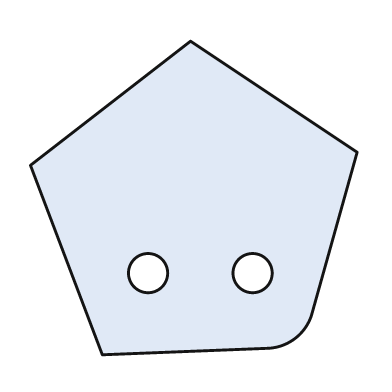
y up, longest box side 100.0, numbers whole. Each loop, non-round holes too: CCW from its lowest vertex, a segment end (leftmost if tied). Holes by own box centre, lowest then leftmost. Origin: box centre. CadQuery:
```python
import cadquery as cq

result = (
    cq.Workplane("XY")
    .moveTo(-28.0, -48.0)
    .lineTo(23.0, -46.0)
    .threePointArc((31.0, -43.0), (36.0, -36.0))
    .lineTo(50.0, 14.0)
    .lineTo(-1.0, 48.0)
    .lineTo(-50.0, 10.0)
    .close()
    .moveTo(-14.0, -23.0)
    .circle(6.0)
    .moveTo(18.0, -23.0)
    .circle(6.0)
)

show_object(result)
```